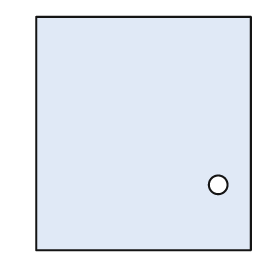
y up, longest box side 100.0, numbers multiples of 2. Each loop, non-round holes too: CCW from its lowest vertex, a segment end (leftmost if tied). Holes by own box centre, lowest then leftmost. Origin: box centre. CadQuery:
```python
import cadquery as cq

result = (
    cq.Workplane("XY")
    .moveTo(-46.0, -50.0)
    .lineTo(46.0, -50.0)
    .lineTo(46.0, 50.0)
    .lineTo(-46.0, 50.0)
    .close()
    .moveTo(32.0, -22.0)
    .circle(4.0)
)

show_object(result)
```